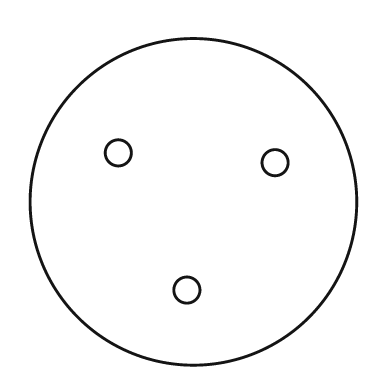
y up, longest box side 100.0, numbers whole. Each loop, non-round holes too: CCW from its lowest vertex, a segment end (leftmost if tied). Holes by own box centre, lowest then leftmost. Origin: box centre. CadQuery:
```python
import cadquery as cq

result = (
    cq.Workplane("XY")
    .moveTo(0.0, 0.0)
    .circle(50.0)
    .moveTo(-2.0, -27.0)
    .circle(4.0)
    .moveTo(25.0, 12.0)
    .circle(4.0)
    .moveTo(-23.0, 15.0)
    .circle(4.0)
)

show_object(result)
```